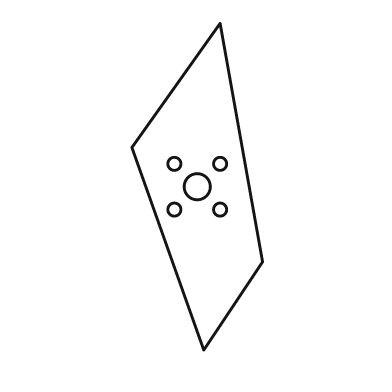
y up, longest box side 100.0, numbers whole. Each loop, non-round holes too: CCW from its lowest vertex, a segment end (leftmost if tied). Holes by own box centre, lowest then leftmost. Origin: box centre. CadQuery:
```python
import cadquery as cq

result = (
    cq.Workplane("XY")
    .moveTo(2.0, -50.0)
    .lineTo(20.0, -23.0)
    .lineTo(7.0, 50.0)
    .lineTo(-20.0, 12.0)
    .close()
    .moveTo(-7.0, -7.0)
    .circle(2.0)
    .moveTo(7.0, -7.0)
    .circle(2.0)
    .moveTo(0.0, 0.0)
    .circle(4.0)
    .moveTo(-7.0, 7.0)
    .circle(2.0)
    .moveTo(7.0, 7.0)
    .circle(2.0)
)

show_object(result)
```